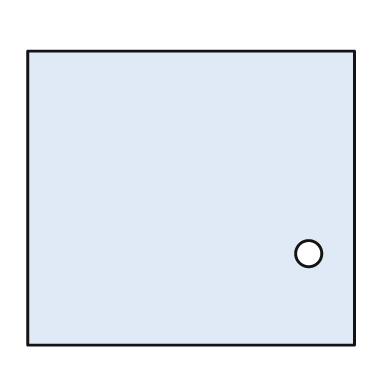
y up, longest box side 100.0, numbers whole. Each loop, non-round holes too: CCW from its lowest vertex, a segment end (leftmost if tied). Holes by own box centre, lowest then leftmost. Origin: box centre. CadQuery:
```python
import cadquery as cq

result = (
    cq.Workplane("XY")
    .moveTo(-50.0, -45.0)
    .lineTo(50.0, -45.0)
    .lineTo(50.0, 45.0)
    .lineTo(-50.0, 45.0)
    .close()
    .moveTo(36.0, -17.0)
    .circle(4.0)
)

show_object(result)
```